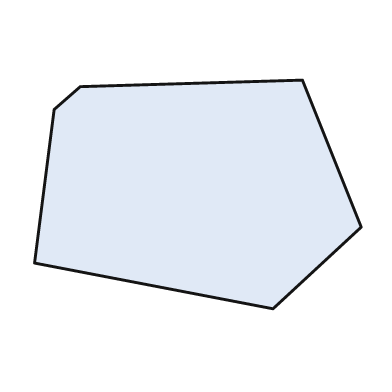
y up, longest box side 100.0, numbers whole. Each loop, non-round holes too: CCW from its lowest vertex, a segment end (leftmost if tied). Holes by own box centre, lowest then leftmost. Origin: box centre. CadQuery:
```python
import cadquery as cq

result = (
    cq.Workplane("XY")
    .moveTo(23.0, -35.0)
    .lineTo(50.0, -10.0)
    .lineTo(32.0, 35.0)
    .lineTo(-36.0, 33.0)
    .lineTo(-44.0, 26.0)
    .lineTo(-50.0, -21.0)
    .close()
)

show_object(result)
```